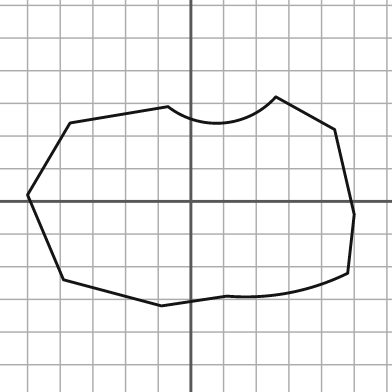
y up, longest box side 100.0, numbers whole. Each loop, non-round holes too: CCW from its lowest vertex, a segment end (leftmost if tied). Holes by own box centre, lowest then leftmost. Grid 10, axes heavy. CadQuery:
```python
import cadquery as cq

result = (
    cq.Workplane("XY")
    .moveTo(-9.0, -32.0)
    .lineTo(11.0, -29.0)
    .threePointArc((30.0, -28.0), (48.0, -22.0))
    .lineTo(50.0, -4.0)
    .lineTo(44.0, 22.0)
    .lineTo(26.0, 32.0)
    .threePointArc((10.0, 24.0), (-7.0, 29.0))
    .lineTo(-37.0, 24.0)
    .lineTo(-50.0, 2.0)
    .lineTo(-39.0, -24.0)
    .close()
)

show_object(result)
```